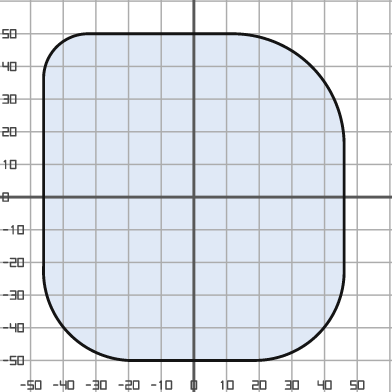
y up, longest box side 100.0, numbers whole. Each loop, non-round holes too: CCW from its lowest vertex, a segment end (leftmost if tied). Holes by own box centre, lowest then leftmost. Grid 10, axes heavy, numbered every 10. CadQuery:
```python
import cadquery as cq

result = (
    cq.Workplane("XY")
    .moveTo(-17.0, -50.0)
    .lineTo(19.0, -50.0)
    .threePointArc((38.0, -42.0), (46.0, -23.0))
    .lineTo(46.0, 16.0)
    .threePointArc((36.0, 40.0), (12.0, 50.0))
    .lineTo(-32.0, 50.0)
    .threePointArc((-42.0, 46.0), (-46.0, 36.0))
    .lineTo(-46.0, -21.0)
    .threePointArc((-38.0, -42.0), (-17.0, -50.0))
    .close()
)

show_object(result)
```